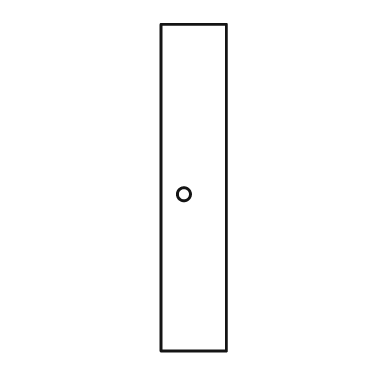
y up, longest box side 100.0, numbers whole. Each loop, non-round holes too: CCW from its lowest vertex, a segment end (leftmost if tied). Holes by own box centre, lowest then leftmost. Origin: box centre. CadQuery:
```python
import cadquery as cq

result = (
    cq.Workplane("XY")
    .moveTo(-10.0, -50.0)
    .lineTo(10.0, -50.0)
    .lineTo(10.0, 50.0)
    .lineTo(-10.0, 50.0)
    .close()
    .moveTo(-3.0, -2.0)
    .circle(2.0)
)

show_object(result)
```